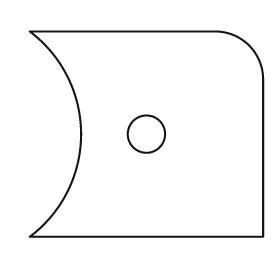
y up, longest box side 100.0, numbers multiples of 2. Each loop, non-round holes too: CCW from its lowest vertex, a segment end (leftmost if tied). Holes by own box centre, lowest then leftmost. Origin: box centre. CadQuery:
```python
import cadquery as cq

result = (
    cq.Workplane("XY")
    .moveTo(-50.0, -44.0)
    .lineTo(50.0, -44.0)
    .lineTo(50.0, 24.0)
    .threePointArc((44.0, 38.0), (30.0, 44.0))
    .lineTo(-50.0, 44.0)
    .threePointArc((-28.0, 0.0), (-50.0, -44.0))
    .close()
    .moveTo(0.0, 0.0)
    .circle(8.0)
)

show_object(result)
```